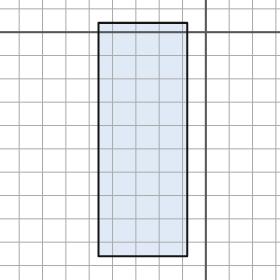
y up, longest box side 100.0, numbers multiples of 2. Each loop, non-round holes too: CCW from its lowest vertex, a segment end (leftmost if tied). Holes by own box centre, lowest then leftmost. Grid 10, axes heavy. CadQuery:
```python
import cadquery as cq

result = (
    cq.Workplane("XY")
    .moveTo(-46.0, -96.0)
    .lineTo(-8.0, -96.0)
    .lineTo(-8.0, 4.0)
    .lineTo(-46.0, 4.0)
    .close()
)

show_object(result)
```